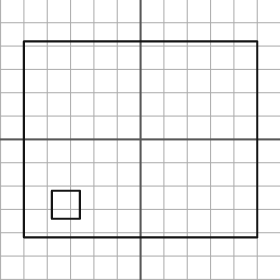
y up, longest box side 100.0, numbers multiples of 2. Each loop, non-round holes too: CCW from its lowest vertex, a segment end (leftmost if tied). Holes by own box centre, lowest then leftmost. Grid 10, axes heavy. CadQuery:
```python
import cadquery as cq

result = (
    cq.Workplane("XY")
    .moveTo(-50.0, -42.0)
    .lineTo(50.0, -42.0)
    .lineTo(50.0, 42.0)
    .lineTo(-50.0, 42.0)
    .close()
    .moveTo(-38.0, -34.0)
    .lineTo(-26.0, -34.0)
    .lineTo(-26.0, -22.0)
    .lineTo(-38.0, -22.0)
    .close()
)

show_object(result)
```